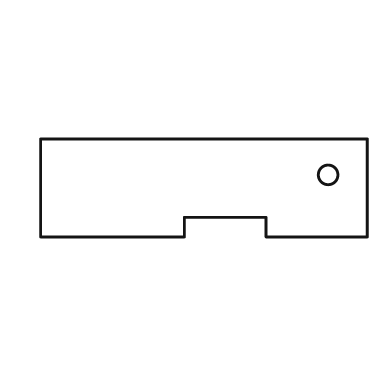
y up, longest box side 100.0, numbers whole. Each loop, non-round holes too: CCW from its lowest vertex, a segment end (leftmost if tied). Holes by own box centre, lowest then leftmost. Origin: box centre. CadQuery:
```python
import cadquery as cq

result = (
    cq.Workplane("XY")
    .moveTo(-50.0, -15.0)
    .lineTo(-6.0, -15.0)
    .lineTo(-6.0, -9.0)
    .lineTo(19.0, -9.0)
    .lineTo(19.0, -15.0)
    .lineTo(50.0, -15.0)
    .lineTo(50.0, 15.0)
    .lineTo(-50.0, 15.0)
    .close()
    .moveTo(38.0, 4.0)
    .circle(3.0)
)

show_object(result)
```